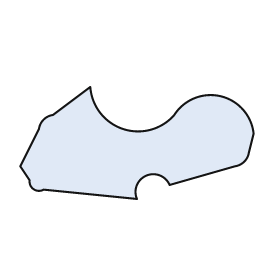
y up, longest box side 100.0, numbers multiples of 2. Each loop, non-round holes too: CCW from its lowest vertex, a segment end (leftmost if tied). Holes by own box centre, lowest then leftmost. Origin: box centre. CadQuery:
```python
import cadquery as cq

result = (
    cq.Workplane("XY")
    .moveTo(0.0, -24.0)
    .threePointArc((4.0, -14.0), (14.0, -18.0))
    .lineTo(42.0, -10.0)
    .threePointArc((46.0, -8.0), (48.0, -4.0))
    .lineTo(50.0, 4.0)
    .threePointArc((36.0, 20.0), (16.0, 12.0))
    .threePointArc((-6.0, 6.0), (-20.0, 24.0))
    .lineTo(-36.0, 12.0)
    .threePointArc((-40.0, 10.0), (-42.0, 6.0))
    .lineTo(-50.0, -10.0)
    .lineTo(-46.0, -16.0)
    .threePointArc((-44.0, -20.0), (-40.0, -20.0))
    .close()
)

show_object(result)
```